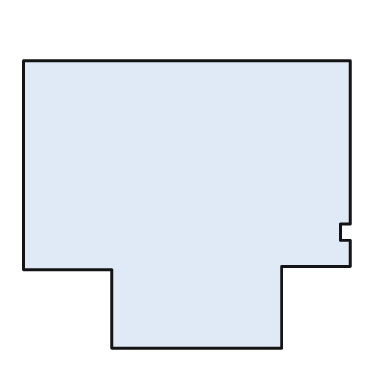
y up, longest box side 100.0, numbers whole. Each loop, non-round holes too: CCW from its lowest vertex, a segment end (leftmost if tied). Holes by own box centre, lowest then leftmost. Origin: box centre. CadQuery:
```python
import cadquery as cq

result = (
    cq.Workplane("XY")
    .moveTo(-23.0, -44.0)
    .lineTo(29.0, -44.0)
    .lineTo(29.0, -19.0)
    .lineTo(50.0, -19.0)
    .lineTo(50.0, -11.0)
    .lineTo(47.0, -11.0)
    .lineTo(47.0, -6.0)
    .lineTo(50.0, -6.0)
    .lineTo(50.0, 44.0)
    .lineTo(-50.0, 44.0)
    .lineTo(-50.0, -20.0)
    .lineTo(-23.0, -20.0)
    .close()
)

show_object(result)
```